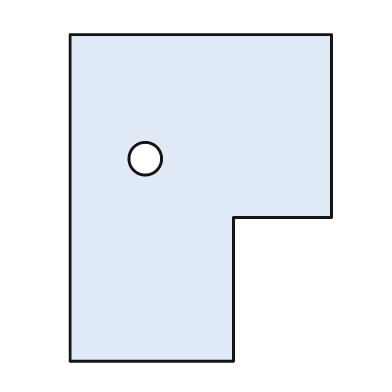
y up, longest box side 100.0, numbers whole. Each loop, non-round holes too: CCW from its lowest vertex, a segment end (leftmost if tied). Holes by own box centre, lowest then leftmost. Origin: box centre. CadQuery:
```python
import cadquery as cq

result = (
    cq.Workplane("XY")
    .moveTo(-40.0, -50.0)
    .lineTo(10.0, -50.0)
    .lineTo(10.0, -6.0)
    .lineTo(40.0, -6.0)
    .lineTo(40.0, 50.0)
    .lineTo(-40.0, 50.0)
    .close()
    .moveTo(-17.0, 12.0)
    .circle(5.0)
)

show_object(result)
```